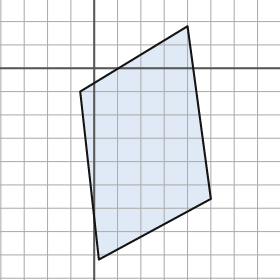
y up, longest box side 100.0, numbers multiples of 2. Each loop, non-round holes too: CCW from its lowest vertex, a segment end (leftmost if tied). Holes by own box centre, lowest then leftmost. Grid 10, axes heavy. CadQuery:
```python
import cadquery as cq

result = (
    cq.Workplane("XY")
    .moveTo(2.0, -82.0)
    .lineTo(50.0, -56.0)
    .lineTo(40.0, 18.0)
    .lineTo(-6.0, -10.0)
    .close()
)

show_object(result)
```